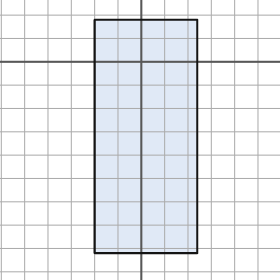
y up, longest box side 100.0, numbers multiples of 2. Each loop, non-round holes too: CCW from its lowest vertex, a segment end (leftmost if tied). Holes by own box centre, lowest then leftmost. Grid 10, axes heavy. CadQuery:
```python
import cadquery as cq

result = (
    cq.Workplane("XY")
    .moveTo(-20.0, -82.0)
    .lineTo(24.0, -82.0)
    .lineTo(24.0, 18.0)
    .lineTo(-20.0, 18.0)
    .close()
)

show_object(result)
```